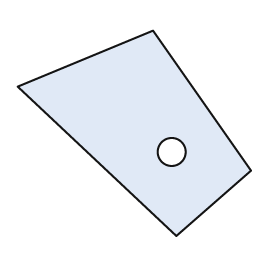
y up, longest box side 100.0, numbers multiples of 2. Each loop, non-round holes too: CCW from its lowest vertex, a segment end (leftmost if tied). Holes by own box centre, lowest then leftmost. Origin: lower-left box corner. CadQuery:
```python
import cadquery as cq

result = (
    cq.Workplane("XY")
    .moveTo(68.0, 0.0)
    .lineTo(100.0, 28.0)
    .lineTo(58.0, 88.0)
    .lineTo(0.0, 64.0)
    .close()
    .moveTo(66.0, 36.0)
    .circle(6.0)
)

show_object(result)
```